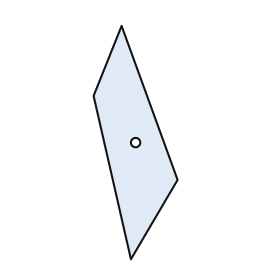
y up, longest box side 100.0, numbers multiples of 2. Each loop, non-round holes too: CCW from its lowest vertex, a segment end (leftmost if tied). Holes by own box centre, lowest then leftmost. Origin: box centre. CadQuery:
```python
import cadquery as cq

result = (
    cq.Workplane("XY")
    .moveTo(-2.0, -50.0)
    .lineTo(18.0, -16.0)
    .lineTo(-6.0, 50.0)
    .lineTo(-18.0, 20.0)
    .close()
    .moveTo(0.0, 0.0)
    .circle(2.0)
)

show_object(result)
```